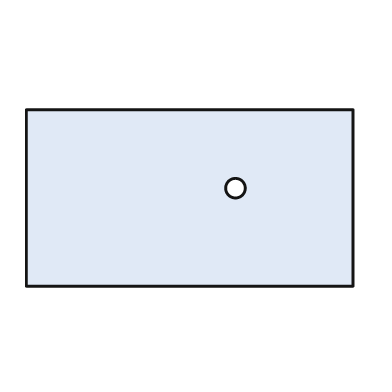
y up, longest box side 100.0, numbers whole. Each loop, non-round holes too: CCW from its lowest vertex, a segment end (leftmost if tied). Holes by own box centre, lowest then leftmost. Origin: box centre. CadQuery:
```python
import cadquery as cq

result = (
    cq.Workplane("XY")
    .moveTo(-50.0, -27.0)
    .lineTo(50.0, -27.0)
    .lineTo(50.0, 27.0)
    .lineTo(-50.0, 27.0)
    .close()
    .moveTo(14.0, 3.0)
    .circle(3.0)
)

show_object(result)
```